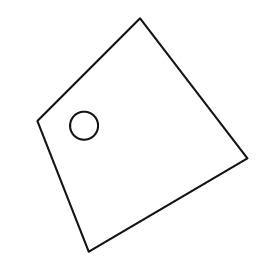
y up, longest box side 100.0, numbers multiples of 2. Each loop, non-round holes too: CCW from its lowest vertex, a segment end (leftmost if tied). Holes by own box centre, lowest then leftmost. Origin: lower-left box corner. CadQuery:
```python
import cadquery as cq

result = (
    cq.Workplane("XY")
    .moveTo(22.0, 0.0)
    .lineTo(90.0, 40.0)
    .lineTo(44.0, 100.0)
    .lineTo(0.0, 56.0)
    .close()
    .moveTo(20.0, 54.0)
    .circle(6.0)
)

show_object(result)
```